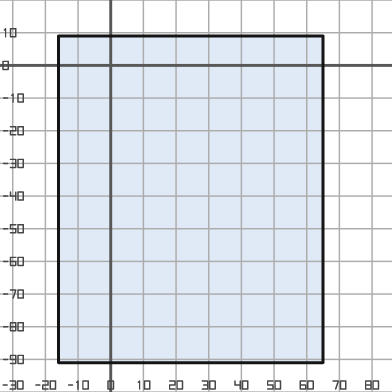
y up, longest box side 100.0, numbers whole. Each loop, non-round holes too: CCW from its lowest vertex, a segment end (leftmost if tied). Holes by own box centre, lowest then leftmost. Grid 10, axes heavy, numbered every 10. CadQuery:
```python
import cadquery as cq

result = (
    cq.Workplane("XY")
    .moveTo(-16.0, -91.0)
    .lineTo(65.0, -91.0)
    .lineTo(65.0, 9.0)
    .lineTo(-16.0, 9.0)
    .close()
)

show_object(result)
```